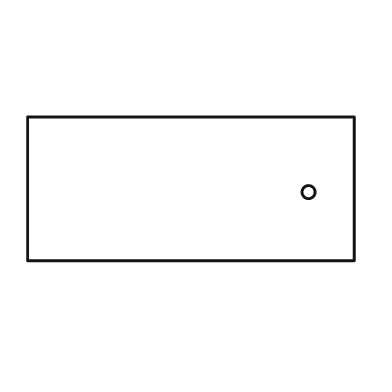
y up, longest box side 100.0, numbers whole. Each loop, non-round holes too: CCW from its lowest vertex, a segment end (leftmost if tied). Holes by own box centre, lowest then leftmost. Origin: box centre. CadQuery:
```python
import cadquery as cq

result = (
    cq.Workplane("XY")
    .moveTo(-50.0, -22.0)
    .lineTo(50.0, -22.0)
    .lineTo(50.0, 22.0)
    .lineTo(-50.0, 22.0)
    .close()
    .moveTo(36.0, -1.0)
    .circle(2.0)
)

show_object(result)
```